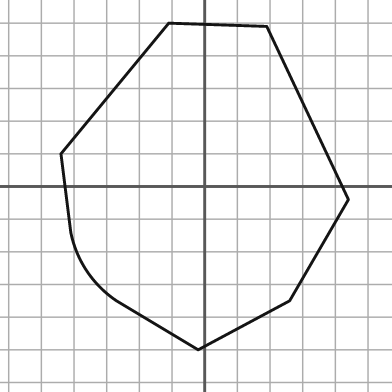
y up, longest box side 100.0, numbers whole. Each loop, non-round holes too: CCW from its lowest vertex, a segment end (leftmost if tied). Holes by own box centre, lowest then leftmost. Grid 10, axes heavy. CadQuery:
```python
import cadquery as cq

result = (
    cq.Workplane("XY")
    .moveTo(-2.0, -50.0)
    .lineTo(26.0, -35.0)
    .lineTo(44.0, -4.0)
    .lineTo(19.0, 49.0)
    .lineTo(-11.0, 50.0)
    .lineTo(-44.0, 10.0)
    .lineTo(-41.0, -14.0)
    .threePointArc((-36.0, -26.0), (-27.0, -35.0))
    .close()
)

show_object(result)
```